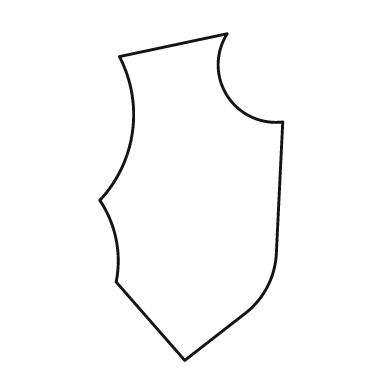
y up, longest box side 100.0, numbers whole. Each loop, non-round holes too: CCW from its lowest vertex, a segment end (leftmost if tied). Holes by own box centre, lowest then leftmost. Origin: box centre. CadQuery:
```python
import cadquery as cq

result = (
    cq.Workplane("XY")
    .moveTo(-2.0, -50.0)
    .lineTo(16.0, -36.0)
    .threePointArc((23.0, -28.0), (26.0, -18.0))
    .lineTo(28.0, 23.0)
    .threePointArc((11.0, 31.0), (11.0, 50.0))
    .lineTo(-22.0, 43.0)
    .threePointArc((-18.0, 20.0), (-28.0, -1.0))
    .threePointArc((-23.0, -13.0), (-23.0, -26.0))
    .close()
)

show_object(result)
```